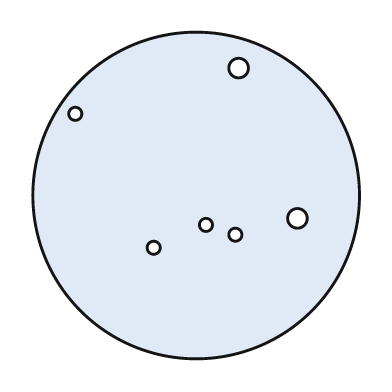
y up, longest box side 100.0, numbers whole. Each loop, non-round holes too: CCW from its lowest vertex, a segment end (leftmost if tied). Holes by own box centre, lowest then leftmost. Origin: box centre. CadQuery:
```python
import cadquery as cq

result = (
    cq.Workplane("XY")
    .moveTo(0.0, 0.0)
    .circle(50.0)
    .moveTo(-13.0, -16.0)
    .circle(2.0)
    .moveTo(12.0, -12.0)
    .circle(2.0)
    .moveTo(3.0, -9.0)
    .circle(2.0)
    .moveTo(31.0, -7.0)
    .circle(3.0)
    .moveTo(-37.0, 25.0)
    .circle(2.0)
    .moveTo(13.0, 39.0)
    .circle(3.0)
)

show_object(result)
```